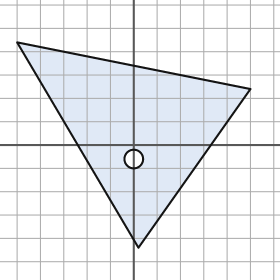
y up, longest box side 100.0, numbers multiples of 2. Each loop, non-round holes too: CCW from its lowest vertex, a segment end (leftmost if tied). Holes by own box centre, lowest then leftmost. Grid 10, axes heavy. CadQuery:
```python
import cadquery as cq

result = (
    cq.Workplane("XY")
    .moveTo(2.0, -44.0)
    .lineTo(50.0, 24.0)
    .lineTo(-50.0, 44.0)
    .close()
    .moveTo(0.0, -6.0)
    .circle(4.0)
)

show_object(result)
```